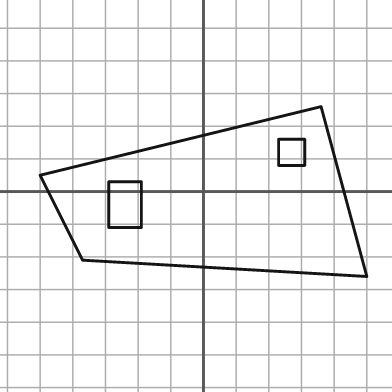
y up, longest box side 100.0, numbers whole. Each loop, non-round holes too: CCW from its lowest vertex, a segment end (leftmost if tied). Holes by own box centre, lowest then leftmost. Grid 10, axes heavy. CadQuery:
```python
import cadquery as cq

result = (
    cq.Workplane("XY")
    .moveTo(50.0, -26.0)
    .lineTo(36.0, 26.0)
    .lineTo(-50.0, 5.0)
    .lineTo(-37.0, -21.0)
    .close()
    .moveTo(-29.0, -11.0)
    .lineTo(-19.0, -11.0)
    .lineTo(-19.0, 3.0)
    .lineTo(-29.0, 3.0)
    .close()
    .moveTo(23.0, 8.0)
    .lineTo(31.0, 8.0)
    .lineTo(31.0, 16.0)
    .lineTo(23.0, 16.0)
    .close()
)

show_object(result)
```